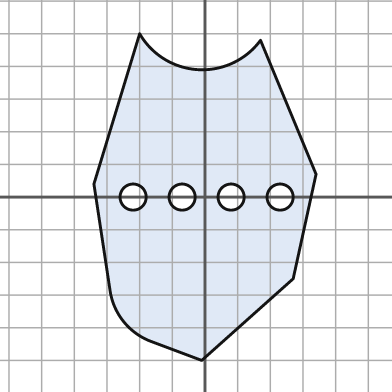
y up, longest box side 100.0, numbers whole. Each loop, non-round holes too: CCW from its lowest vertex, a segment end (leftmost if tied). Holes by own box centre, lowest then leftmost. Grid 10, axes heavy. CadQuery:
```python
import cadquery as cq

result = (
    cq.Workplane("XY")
    .moveTo(-1.0, -50.0)
    .lineTo(27.0, -25.0)
    .lineTo(34.0, 7.0)
    .lineTo(17.0, 48.0)
    .threePointArc((-2.0, 39.0), (-20.0, 50.0))
    .lineTo(-34.0, 4.0)
    .lineTo(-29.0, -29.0)
    .threePointArc((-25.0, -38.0), (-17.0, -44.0))
    .close()
    .moveTo(-22.0, 0.0)
    .circle(4.0)
    .moveTo(-7.0, 0.0)
    .circle(4.0)
    .moveTo(8.0, 0.0)
    .circle(4.0)
    .moveTo(23.0, 0.0)
    .circle(4.0)
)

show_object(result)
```